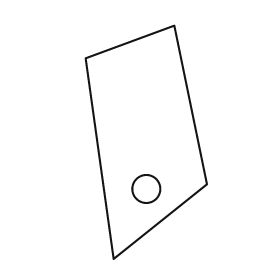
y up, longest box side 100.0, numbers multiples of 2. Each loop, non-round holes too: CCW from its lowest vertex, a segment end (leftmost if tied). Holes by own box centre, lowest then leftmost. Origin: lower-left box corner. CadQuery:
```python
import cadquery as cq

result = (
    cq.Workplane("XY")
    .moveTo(12.0, 0.0)
    .lineTo(52.0, 32.0)
    .lineTo(38.0, 100.0)
    .lineTo(0.0, 86.0)
    .close()
    .moveTo(26.0, 30.0)
    .circle(6.0)
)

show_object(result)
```